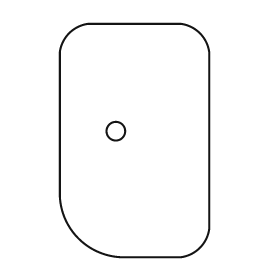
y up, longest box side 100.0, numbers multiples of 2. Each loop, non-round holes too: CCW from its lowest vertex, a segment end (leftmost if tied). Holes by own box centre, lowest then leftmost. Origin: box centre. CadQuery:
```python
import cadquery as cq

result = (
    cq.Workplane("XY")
    .moveTo(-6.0, -50.0)
    .lineTo(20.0, -50.0)
    .threePointArc((28.0, -46.0), (32.0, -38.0))
    .lineTo(32.0, 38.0)
    .threePointArc((28.0, 46.0), (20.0, 50.0))
    .lineTo(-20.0, 50.0)
    .threePointArc((-28.0, 46.0), (-32.0, 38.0))
    .lineTo(-32.0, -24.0)
    .threePointArc((-24.0, -42.0), (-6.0, -50.0))
    .close()
    .moveTo(-8.0, 4.0)
    .circle(4.0)
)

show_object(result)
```